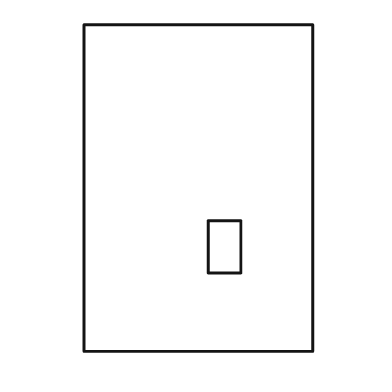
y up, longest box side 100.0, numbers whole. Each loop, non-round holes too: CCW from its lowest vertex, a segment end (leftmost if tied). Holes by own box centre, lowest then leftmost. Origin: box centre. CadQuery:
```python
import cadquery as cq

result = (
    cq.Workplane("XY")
    .moveTo(-35.0, -50.0)
    .lineTo(35.0, -50.0)
    .lineTo(35.0, 50.0)
    .lineTo(-35.0, 50.0)
    .close()
    .moveTo(3.0, -26.0)
    .lineTo(13.0, -26.0)
    .lineTo(13.0, -10.0)
    .lineTo(3.0, -10.0)
    .close()
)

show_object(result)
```